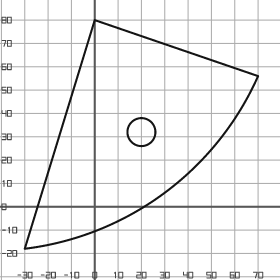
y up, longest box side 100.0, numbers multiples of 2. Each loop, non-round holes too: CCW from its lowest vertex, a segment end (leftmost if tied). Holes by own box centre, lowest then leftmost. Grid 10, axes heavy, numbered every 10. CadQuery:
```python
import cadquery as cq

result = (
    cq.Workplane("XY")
    .moveTo(-30.0, -18.0)
    .threePointArc((30.0, 6.0), (70.0, 56.0))
    .lineTo(0.0, 80.0)
    .close()
    .moveTo(20.0, 32.0)
    .circle(6.0)
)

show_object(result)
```